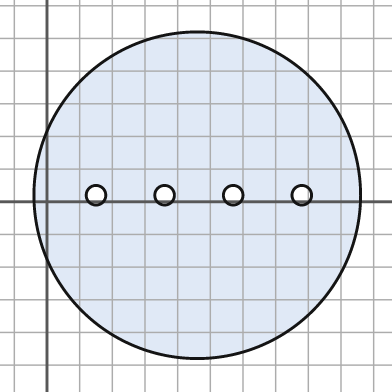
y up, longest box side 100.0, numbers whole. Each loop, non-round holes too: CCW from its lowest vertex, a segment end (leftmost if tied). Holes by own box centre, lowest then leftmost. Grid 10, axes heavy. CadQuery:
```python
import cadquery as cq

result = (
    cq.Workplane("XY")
    .moveTo(46.0, 2.0)
    .circle(50.0)
    .moveTo(15.0, 2.0)
    .circle(3.0)
    .moveTo(36.0, 2.0)
    .circle(3.0)
    .moveTo(57.0, 2.0)
    .circle(3.0)
    .moveTo(78.0, 2.0)
    .circle(3.0)
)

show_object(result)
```